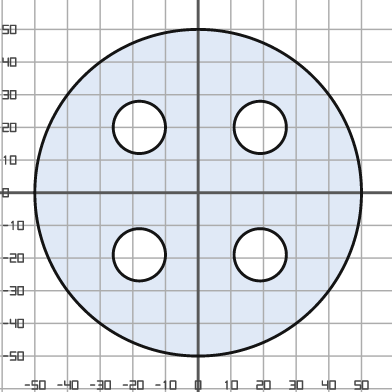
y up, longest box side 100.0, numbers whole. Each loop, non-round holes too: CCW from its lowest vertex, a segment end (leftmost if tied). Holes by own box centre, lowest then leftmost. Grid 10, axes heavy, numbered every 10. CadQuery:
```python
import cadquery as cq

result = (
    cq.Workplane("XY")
    .moveTo(0.0, 0.0)
    .circle(50.0)
    .moveTo(-18.0, -19.0)
    .circle(8.0)
    .moveTo(19.0, -19.0)
    .circle(8.0)
    .moveTo(-18.0, 20.0)
    .circle(8.0)
    .moveTo(19.0, 20.0)
    .circle(8.0)
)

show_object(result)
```